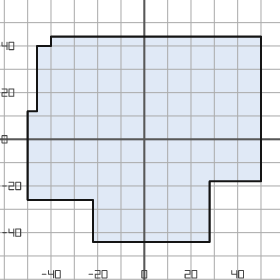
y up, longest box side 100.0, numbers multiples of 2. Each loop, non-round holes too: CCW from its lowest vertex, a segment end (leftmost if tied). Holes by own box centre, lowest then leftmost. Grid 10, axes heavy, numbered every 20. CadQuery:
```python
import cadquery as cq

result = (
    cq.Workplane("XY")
    .moveTo(-22.0, -44.0)
    .lineTo(28.0, -44.0)
    .lineTo(28.0, -18.0)
    .lineTo(50.0, -18.0)
    .lineTo(50.0, 44.0)
    .lineTo(-40.0, 44.0)
    .lineTo(-40.0, 40.0)
    .lineTo(-46.0, 40.0)
    .lineTo(-46.0, 12.0)
    .lineTo(-50.0, 12.0)
    .lineTo(-50.0, -26.0)
    .lineTo(-22.0, -26.0)
    .close()
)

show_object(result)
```